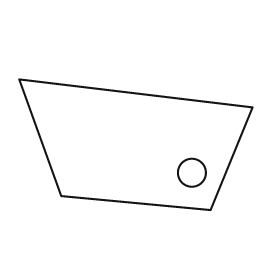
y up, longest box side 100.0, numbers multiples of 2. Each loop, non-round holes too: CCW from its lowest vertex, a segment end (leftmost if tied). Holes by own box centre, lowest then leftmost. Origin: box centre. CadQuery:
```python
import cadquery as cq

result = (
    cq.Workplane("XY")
    .moveTo(32.0, -28.0)
    .lineTo(50.0, 16.0)
    .lineTo(-50.0, 28.0)
    .lineTo(-32.0, -22.0)
    .close()
    .moveTo(24.0, -12.0)
    .circle(6.0)
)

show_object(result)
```